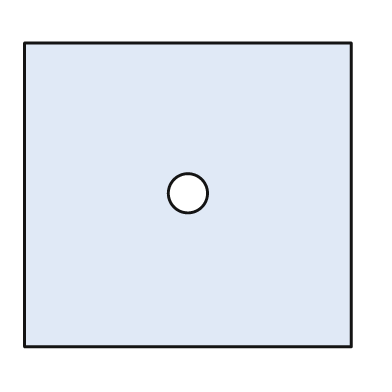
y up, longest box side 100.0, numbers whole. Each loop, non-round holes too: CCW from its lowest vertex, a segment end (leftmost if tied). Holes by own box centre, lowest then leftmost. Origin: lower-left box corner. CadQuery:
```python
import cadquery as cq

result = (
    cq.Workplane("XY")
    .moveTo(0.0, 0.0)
    .lineTo(100.0, 0.0)
    .lineTo(100.0, 93.0)
    .lineTo(0.0, 93.0)
    .close()
    .moveTo(50.0, 47.0)
    .circle(6.0)
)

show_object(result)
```